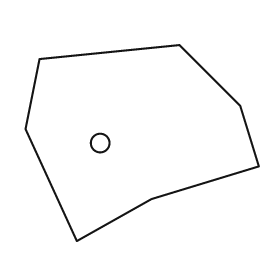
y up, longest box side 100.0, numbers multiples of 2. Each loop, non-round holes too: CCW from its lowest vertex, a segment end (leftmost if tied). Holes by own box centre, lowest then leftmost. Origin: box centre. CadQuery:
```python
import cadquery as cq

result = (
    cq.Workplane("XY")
    .moveTo(-28.0, -42.0)
    .lineTo(4.0, -24.0)
    .lineTo(50.0, -10.0)
    .lineTo(42.0, 16.0)
    .lineTo(16.0, 42.0)
    .lineTo(-44.0, 36.0)
    .lineTo(-50.0, 6.0)
    .close()
    .moveTo(-18.0, 0.0)
    .circle(4.0)
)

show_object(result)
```